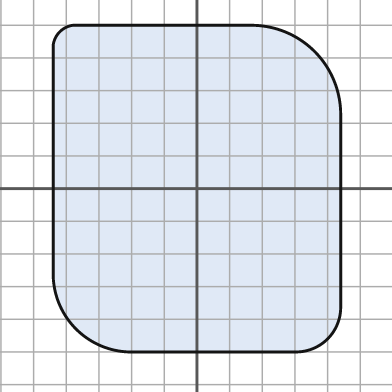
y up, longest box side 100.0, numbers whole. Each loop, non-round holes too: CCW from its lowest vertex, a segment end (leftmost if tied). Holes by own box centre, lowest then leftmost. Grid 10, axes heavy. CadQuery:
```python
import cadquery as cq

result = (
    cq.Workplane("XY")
    .moveTo(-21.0, -50.0)
    .lineTo(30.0, -50.0)
    .threePointArc((40.0, -46.0), (44.0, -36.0))
    .lineTo(44.0, 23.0)
    .threePointArc((36.0, 42.0), (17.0, 50.0))
    .lineTo(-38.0, 50.0)
    .threePointArc((-42.0, 48.0), (-44.0, 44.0))
    .lineTo(-44.0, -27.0)
    .threePointArc((-37.0, -43.0), (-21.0, -50.0))
    .close()
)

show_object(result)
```